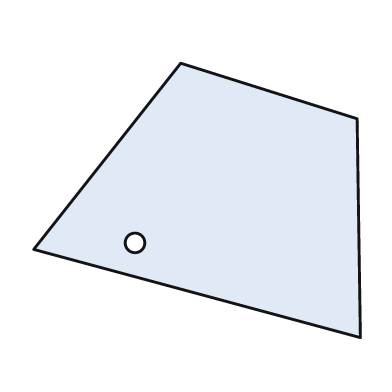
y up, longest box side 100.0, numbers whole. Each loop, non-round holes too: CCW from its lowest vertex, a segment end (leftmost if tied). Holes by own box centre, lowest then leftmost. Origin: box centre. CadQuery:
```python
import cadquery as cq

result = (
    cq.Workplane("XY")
    .moveTo(50.0, -42.0)
    .lineTo(49.0, 25.0)
    .lineTo(-5.0, 42.0)
    .lineTo(-50.0, -15.0)
    .close()
    .moveTo(-19.0, -13.0)
    .circle(3.0)
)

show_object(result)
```